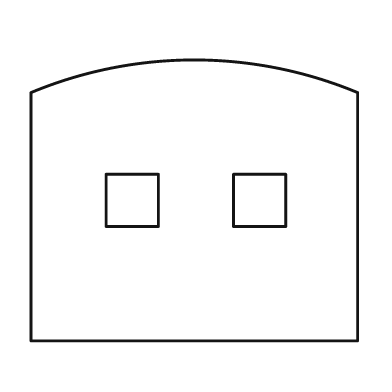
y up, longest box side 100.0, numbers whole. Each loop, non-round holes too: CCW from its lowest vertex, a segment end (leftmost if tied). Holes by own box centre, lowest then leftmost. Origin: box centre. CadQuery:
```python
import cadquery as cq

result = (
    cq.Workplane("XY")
    .moveTo(-50.0, -43.0)
    .lineTo(50.0, -43.0)
    .lineTo(50.0, 33.0)
    .threePointArc((0.0, 43.0), (-50.0, 33.0))
    .close()
    .moveTo(-27.0, -8.0)
    .lineTo(-11.0, -8.0)
    .lineTo(-11.0, 8.0)
    .lineTo(-27.0, 8.0)
    .close()
    .moveTo(12.0, -8.0)
    .lineTo(28.0, -8.0)
    .lineTo(28.0, 8.0)
    .lineTo(12.0, 8.0)
    .close()
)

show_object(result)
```